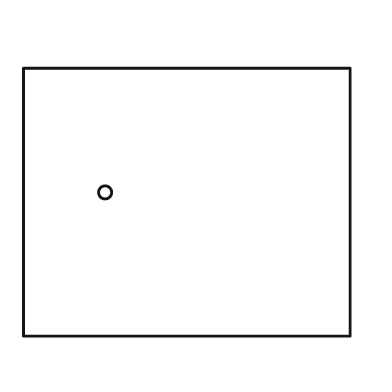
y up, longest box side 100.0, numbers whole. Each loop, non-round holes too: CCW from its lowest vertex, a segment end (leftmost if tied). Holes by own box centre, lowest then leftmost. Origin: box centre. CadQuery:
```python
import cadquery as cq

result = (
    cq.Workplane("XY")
    .moveTo(-50.0, -41.0)
    .lineTo(50.0, -41.0)
    .lineTo(50.0, 41.0)
    .lineTo(-50.0, 41.0)
    .close()
    .moveTo(-25.0, 3.0)
    .circle(2.0)
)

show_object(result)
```